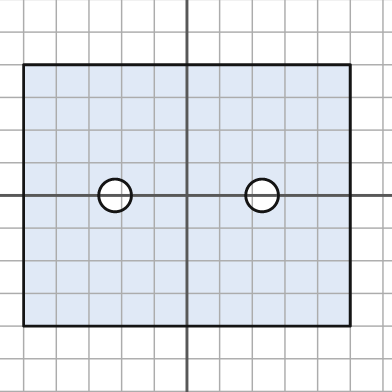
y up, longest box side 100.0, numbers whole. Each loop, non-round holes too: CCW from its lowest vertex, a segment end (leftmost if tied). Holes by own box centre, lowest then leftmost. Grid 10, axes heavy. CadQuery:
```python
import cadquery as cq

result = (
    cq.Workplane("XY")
    .moveTo(-50.0, -40.0)
    .lineTo(50.0, -40.0)
    .lineTo(50.0, 40.0)
    .lineTo(-50.0, 40.0)
    .close()
    .moveTo(-22.0, 0.0)
    .circle(5.0)
    .moveTo(23.0, 0.0)
    .circle(5.0)
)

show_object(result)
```